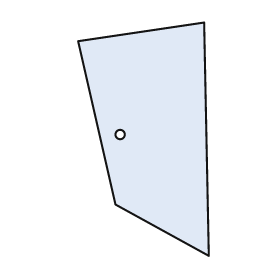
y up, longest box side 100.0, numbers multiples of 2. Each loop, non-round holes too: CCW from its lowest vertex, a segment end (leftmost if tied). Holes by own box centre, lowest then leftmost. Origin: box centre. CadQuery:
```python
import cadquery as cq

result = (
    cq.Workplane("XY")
    .moveTo(28.0, -50.0)
    .lineTo(26.0, 50.0)
    .lineTo(-28.0, 42.0)
    .lineTo(-12.0, -28.0)
    .close()
    .moveTo(-10.0, 2.0)
    .circle(2.0)
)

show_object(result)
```